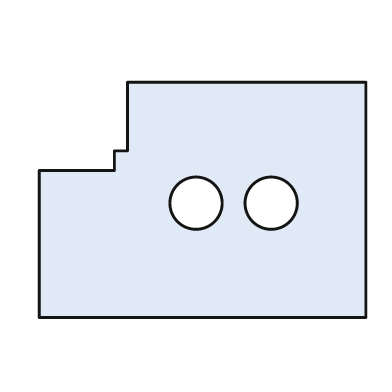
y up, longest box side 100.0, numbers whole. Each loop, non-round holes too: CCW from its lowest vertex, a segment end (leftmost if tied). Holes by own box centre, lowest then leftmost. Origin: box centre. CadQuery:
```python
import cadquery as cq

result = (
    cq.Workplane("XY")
    .moveTo(-50.0, -36.0)
    .lineTo(50.0, -36.0)
    .lineTo(50.0, 36.0)
    .lineTo(-23.0, 36.0)
    .lineTo(-23.0, 15.0)
    .lineTo(-27.0, 15.0)
    .lineTo(-27.0, 9.0)
    .lineTo(-50.0, 9.0)
    .close()
    .moveTo(-2.0, -1.0)
    .circle(8.0)
    .moveTo(21.0, -1.0)
    .circle(8.0)
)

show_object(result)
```